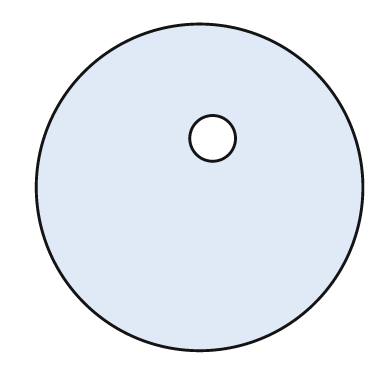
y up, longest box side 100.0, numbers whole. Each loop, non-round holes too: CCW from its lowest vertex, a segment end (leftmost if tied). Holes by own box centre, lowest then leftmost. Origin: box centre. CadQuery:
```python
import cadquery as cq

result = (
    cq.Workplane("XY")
    .moveTo(0.0, 0.0)
    .circle(50.0)
    .moveTo(4.0, 15.0)
    .circle(7.0)
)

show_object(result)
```